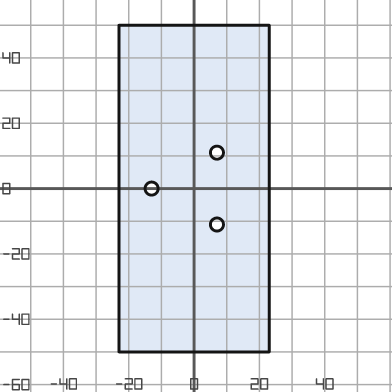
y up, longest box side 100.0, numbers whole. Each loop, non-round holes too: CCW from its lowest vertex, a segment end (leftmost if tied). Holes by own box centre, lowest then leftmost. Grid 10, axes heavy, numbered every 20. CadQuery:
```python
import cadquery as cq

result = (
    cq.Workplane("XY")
    .moveTo(-23.0, -50.0)
    .lineTo(23.0, -50.0)
    .lineTo(23.0, 50.0)
    .lineTo(-23.0, 50.0)
    .close()
    .moveTo(7.0, -11.0)
    .circle(2.0)
    .moveTo(-13.0, 0.0)
    .circle(2.0)
    .moveTo(7.0, 11.0)
    .circle(2.0)
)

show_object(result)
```